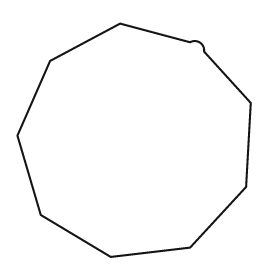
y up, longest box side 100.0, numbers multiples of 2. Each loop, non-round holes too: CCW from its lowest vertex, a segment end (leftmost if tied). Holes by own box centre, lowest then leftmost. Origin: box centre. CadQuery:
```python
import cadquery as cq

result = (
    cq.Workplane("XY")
    .moveTo(-10.0, -50.0)
    .lineTo(24.0, -46.0)
    .lineTo(48.0, -20.0)
    .lineTo(50.0, 16.0)
    .lineTo(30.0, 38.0)
    .threePointArc((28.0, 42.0), (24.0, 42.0))
    .lineTo(-6.0, 50.0)
    .lineTo(-36.0, 34.0)
    .lineTo(-50.0, 2.0)
    .lineTo(-40.0, -32.0)
    .close()
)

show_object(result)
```